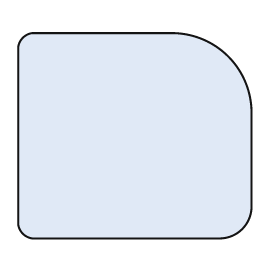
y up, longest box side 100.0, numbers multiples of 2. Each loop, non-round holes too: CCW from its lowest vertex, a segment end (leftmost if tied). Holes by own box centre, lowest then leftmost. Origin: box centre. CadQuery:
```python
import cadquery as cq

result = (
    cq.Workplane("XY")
    .moveTo(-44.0, -44.0)
    .lineTo(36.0, -44.0)
    .threePointArc((46.0, -40.0), (50.0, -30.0))
    .lineTo(50.0, 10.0)
    .threePointArc((40.0, 34.0), (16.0, 44.0))
    .lineTo(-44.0, 44.0)
    .threePointArc((-48.0, 42.0), (-50.0, 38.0))
    .lineTo(-50.0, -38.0)
    .threePointArc((-48.0, -42.0), (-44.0, -44.0))
    .close()
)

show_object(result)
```